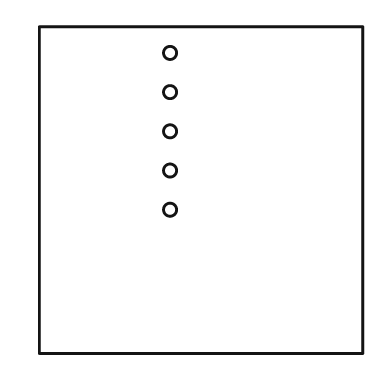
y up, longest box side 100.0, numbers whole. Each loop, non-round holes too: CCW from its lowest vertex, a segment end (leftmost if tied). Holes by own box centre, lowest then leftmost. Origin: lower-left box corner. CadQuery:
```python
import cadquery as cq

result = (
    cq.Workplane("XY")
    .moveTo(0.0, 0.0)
    .lineTo(99.0, 0.0)
    .lineTo(99.0, 100.0)
    .lineTo(0.0, 100.0)
    .close()
    .moveTo(40.0, 44.0)
    .circle(2.0)
    .moveTo(40.0, 56.0)
    .circle(2.0)
    .moveTo(40.0, 68.0)
    .circle(2.0)
    .moveTo(40.0, 80.0)
    .circle(2.0)
    .moveTo(40.0, 92.0)
    .circle(2.0)
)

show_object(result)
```